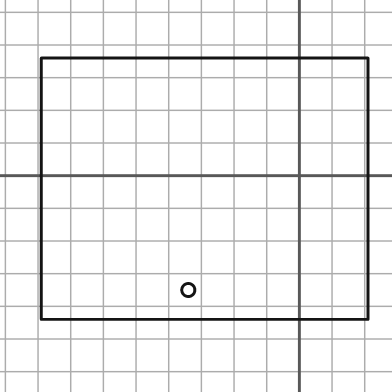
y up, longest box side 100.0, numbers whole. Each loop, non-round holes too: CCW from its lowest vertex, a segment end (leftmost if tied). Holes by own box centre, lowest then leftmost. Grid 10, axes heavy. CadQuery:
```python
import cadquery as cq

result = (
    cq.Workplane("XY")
    .moveTo(-79.0, -44.0)
    .lineTo(21.0, -44.0)
    .lineTo(21.0, 36.0)
    .lineTo(-79.0, 36.0)
    .close()
    .moveTo(-34.0, -35.0)
    .circle(2.0)
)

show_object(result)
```